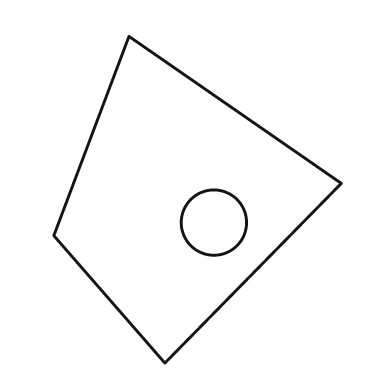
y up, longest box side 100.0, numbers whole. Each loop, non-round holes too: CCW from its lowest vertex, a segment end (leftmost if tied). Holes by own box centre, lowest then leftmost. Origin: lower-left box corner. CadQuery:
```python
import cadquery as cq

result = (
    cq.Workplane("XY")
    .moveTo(34.0, 0.0)
    .lineTo(88.0, 55.0)
    .lineTo(23.0, 100.0)
    .lineTo(0.0, 39.0)
    .close()
    .moveTo(49.0, 43.0)
    .circle(10.0)
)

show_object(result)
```